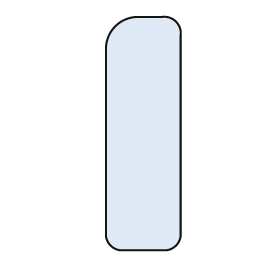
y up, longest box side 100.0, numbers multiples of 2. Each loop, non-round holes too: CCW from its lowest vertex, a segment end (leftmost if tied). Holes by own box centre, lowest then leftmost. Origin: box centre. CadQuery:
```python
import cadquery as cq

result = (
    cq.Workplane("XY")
    .moveTo(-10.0, -50.0)
    .lineTo(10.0, -50.0)
    .threePointArc((14.0, -48.0), (16.0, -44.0))
    .lineTo(16.0, 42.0)
    .threePointArc((14.0, 48.0), (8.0, 50.0))
    .lineTo(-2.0, 50.0)
    .threePointArc((-12.0, 46.0), (-16.0, 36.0))
    .lineTo(-16.0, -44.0)
    .threePointArc((-14.0, -48.0), (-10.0, -50.0))
    .close()
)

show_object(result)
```